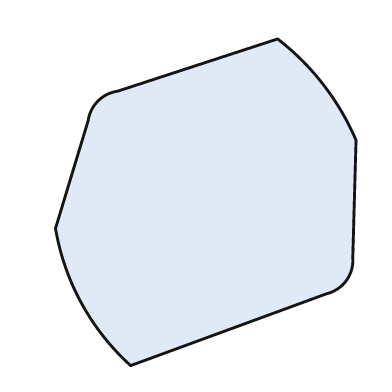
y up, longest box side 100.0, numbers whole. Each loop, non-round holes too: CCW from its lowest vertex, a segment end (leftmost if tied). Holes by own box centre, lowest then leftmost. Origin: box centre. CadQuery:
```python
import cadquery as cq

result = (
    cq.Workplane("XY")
    .moveTo(-23.0, -50.0)
    .lineTo(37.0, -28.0)
    .threePointArc((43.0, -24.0), (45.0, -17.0))
    .lineTo(46.0, 19.0)
    .threePointArc((36.0, 36.0), (22.0, 50.0))
    .lineTo(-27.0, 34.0)
    .threePointArc((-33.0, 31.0), (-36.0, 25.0))
    .lineTo(-46.0, -8.0)
    .threePointArc((-38.0, -31.0), (-23.0, -50.0))
    .close()
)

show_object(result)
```